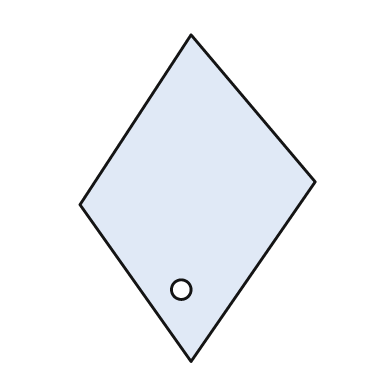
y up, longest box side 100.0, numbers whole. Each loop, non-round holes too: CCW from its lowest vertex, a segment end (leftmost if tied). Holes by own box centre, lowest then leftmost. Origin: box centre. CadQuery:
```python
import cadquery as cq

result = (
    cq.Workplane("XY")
    .moveTo(-2.0, -50.0)
    .lineTo(36.0, 5.0)
    .lineTo(-2.0, 50.0)
    .lineTo(-36.0, -2.0)
    .close()
    .moveTo(-5.0, -28.0)
    .circle(3.0)
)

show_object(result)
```